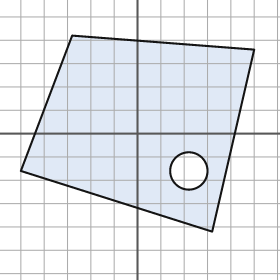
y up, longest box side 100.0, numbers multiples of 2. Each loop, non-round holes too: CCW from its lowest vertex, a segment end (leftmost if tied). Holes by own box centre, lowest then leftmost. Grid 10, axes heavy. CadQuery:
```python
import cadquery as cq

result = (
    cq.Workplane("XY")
    .moveTo(32.0, -42.0)
    .lineTo(50.0, 36.0)
    .lineTo(-28.0, 42.0)
    .lineTo(-50.0, -16.0)
    .close()
    .moveTo(22.0, -16.0)
    .circle(8.0)
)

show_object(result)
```